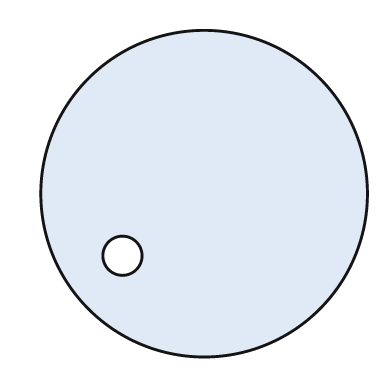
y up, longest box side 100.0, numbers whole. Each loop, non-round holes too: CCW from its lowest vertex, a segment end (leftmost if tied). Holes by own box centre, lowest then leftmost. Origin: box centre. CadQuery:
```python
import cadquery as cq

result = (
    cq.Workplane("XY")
    .moveTo(0.0, 0.0)
    .circle(50.0)
    .moveTo(-25.0, -19.0)
    .circle(6.0)
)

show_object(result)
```